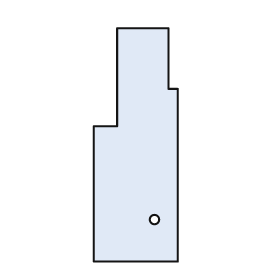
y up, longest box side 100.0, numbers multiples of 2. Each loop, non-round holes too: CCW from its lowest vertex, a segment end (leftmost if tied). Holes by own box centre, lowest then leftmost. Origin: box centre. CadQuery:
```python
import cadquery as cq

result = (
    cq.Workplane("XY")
    .moveTo(-18.0, -50.0)
    .lineTo(18.0, -50.0)
    .lineTo(18.0, 24.0)
    .lineTo(14.0, 24.0)
    .lineTo(14.0, 50.0)
    .lineTo(-8.0, 50.0)
    .lineTo(-8.0, 8.0)
    .lineTo(-18.0, 8.0)
    .close()
    .moveTo(8.0, -32.0)
    .circle(2.0)
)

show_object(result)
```